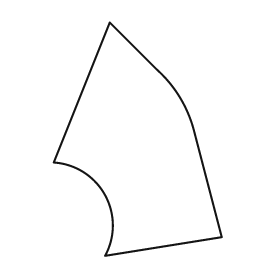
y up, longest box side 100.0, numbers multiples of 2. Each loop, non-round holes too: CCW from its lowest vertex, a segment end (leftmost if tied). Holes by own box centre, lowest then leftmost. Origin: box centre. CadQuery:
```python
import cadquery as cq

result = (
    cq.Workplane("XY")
    .moveTo(-14.0, -50.0)
    .lineTo(36.0, -42.0)
    .lineTo(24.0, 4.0)
    .threePointArc((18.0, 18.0), (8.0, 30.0))
    .lineTo(-12.0, 50.0)
    .lineTo(-36.0, -10.0)
    .threePointArc((-14.0, -24.0), (-14.0, -50.0))
    .close()
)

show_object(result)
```